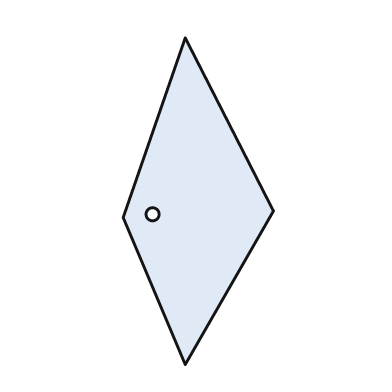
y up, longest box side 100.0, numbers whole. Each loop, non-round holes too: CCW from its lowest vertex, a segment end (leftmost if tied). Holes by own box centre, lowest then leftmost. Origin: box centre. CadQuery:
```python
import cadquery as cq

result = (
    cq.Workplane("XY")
    .moveTo(-4.0, -50.0)
    .lineTo(23.0, -3.0)
    .lineTo(-4.0, 50.0)
    .lineTo(-23.0, -5.0)
    .close()
    .moveTo(-14.0, -4.0)
    .circle(2.0)
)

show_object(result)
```